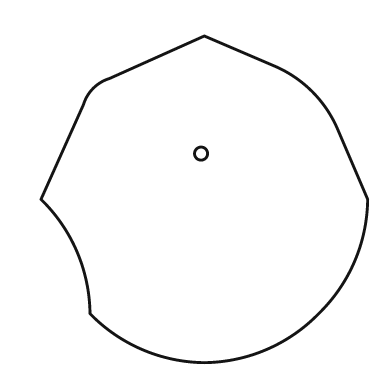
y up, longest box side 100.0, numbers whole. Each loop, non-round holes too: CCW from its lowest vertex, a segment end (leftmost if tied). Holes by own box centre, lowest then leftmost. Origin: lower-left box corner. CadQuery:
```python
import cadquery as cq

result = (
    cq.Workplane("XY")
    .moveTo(50.0, 0.0)
    .threePointArc((69.0, 4.0), (85.0, 15.0))
    .threePointArc((96.0, 31.0), (100.0, 50.0))
    .lineTo(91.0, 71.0)
    .threePointArc((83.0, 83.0), (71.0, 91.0))
    .lineTo(50.0, 100.0)
    .lineTo(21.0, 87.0)
    .threePointArc((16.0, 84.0), (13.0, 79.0))
    .lineTo(0.0, 50.0)
    .threePointArc((11.0, 34.0), (15.0, 15.0))
    .threePointArc((31.0, 4.0), (50.0, 0.0))
    .close()
    .moveTo(49.0, 64.0)
    .circle(2.0)
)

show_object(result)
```